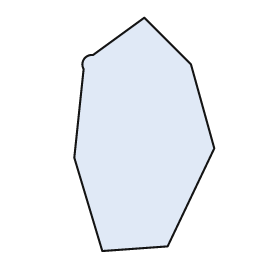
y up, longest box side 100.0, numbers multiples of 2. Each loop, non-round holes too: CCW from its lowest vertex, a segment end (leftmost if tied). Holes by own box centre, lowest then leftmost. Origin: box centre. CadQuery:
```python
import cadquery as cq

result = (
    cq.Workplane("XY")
    .moveTo(-18.0, -50.0)
    .lineTo(10.0, -48.0)
    .lineTo(30.0, -6.0)
    .lineTo(20.0, 30.0)
    .lineTo(0.0, 50.0)
    .lineTo(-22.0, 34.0)
    .threePointArc((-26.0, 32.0), (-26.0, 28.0))
    .lineTo(-30.0, -10.0)
    .close()
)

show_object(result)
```